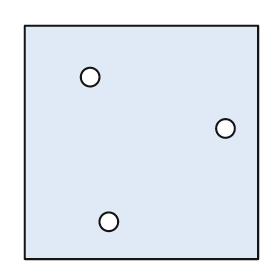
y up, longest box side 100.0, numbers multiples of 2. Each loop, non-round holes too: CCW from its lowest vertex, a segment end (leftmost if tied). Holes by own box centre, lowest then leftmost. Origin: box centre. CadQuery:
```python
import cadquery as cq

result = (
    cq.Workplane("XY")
    .moveTo(-50.0, -50.0)
    .lineTo(50.0, -50.0)
    .lineTo(50.0, 50.0)
    .lineTo(-50.0, 50.0)
    .close()
    .moveTo(-14.0, -34.0)
    .circle(4.0)
    .moveTo(36.0, 6.0)
    .circle(4.0)
    .moveTo(-22.0, 28.0)
    .circle(4.0)
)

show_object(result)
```